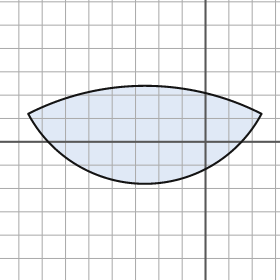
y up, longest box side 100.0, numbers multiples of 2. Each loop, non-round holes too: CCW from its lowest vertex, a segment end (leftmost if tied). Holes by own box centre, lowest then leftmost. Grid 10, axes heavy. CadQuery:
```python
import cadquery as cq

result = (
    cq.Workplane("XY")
    .moveTo(-76.0, 12.0)
    .threePointArc((-26.0, -18.0), (24.0, 12.0))
    .threePointArc((-26.0, 24.0), (-76.0, 12.0))
    .close()
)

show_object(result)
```